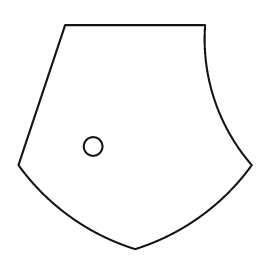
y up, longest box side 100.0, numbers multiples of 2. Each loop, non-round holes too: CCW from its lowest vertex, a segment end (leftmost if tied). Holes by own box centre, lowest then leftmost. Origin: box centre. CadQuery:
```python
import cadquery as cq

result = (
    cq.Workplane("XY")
    .moveTo(0.0, -48.0)
    .threePointArc((28.0, -34.0), (50.0, -12.0))
    .threePointArc((34.0, 16.0), (30.0, 48.0))
    .lineTo(-30.0, 48.0)
    .lineTo(-50.0, -12.0)
    .threePointArc((-28.0, -34.0), (0.0, -48.0))
    .close()
    .moveTo(-18.0, -4.0)
    .circle(4.0)
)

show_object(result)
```